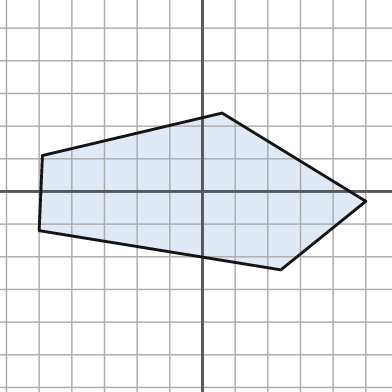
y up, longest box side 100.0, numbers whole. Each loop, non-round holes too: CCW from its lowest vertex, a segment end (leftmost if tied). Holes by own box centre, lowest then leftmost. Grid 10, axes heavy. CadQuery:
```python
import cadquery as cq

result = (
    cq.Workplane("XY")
    .moveTo(24.0, -24.0)
    .lineTo(50.0, -3.0)
    .lineTo(6.0, 24.0)
    .lineTo(-49.0, 11.0)
    .lineTo(-50.0, -12.0)
    .close()
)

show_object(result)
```